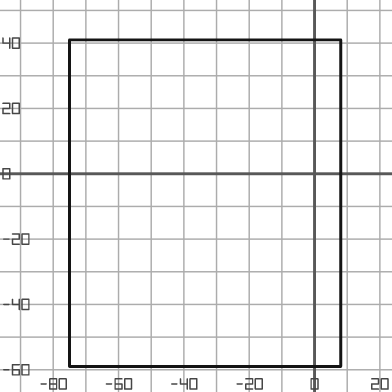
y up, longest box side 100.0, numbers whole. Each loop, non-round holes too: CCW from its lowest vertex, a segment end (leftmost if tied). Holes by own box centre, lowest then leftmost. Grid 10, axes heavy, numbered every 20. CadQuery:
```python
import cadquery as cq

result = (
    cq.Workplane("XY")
    .moveTo(-75.0, -59.0)
    .lineTo(8.0, -59.0)
    .lineTo(8.0, 41.0)
    .lineTo(-75.0, 41.0)
    .close()
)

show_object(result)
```